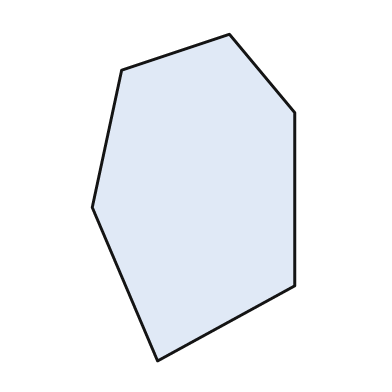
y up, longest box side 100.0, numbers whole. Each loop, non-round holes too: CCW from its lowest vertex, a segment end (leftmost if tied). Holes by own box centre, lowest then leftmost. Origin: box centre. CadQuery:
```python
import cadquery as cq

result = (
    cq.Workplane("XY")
    .moveTo(-11.0, -50.0)
    .lineTo(31.0, -27.0)
    .lineTo(31.0, 26.0)
    .lineTo(11.0, 50.0)
    .lineTo(-22.0, 39.0)
    .lineTo(-31.0, -3.0)
    .close()
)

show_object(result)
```